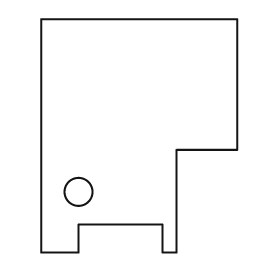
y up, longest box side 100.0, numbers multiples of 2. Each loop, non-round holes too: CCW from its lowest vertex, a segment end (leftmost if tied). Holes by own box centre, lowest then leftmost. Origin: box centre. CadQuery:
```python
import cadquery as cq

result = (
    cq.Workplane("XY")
    .moveTo(-42.0, -50.0)
    .lineTo(-26.0, -50.0)
    .lineTo(-26.0, -38.0)
    .lineTo(10.0, -38.0)
    .lineTo(10.0, -50.0)
    .lineTo(16.0, -50.0)
    .lineTo(16.0, -6.0)
    .lineTo(42.0, -6.0)
    .lineTo(42.0, 50.0)
    .lineTo(-42.0, 50.0)
    .close()
    .moveTo(-26.0, -24.0)
    .circle(6.0)
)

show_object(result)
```